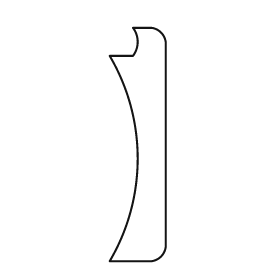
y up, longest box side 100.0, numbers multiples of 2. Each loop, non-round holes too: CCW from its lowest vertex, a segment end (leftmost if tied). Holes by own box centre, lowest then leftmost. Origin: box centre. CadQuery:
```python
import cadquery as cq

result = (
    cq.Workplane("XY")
    .moveTo(-12.0, -50.0)
    .lineTo(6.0, -50.0)
    .threePointArc((10.0, -48.0), (12.0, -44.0))
    .lineTo(12.0, 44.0)
    .threePointArc((10.0, 48.0), (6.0, 50.0))
    .lineTo(-2.0, 50.0)
    .threePointArc((0.0, 44.0), (-2.0, 38.0))
    .lineTo(-12.0, 38.0)
    .threePointArc((0.0, -6.0), (-12.0, -50.0))
    .close()
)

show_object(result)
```